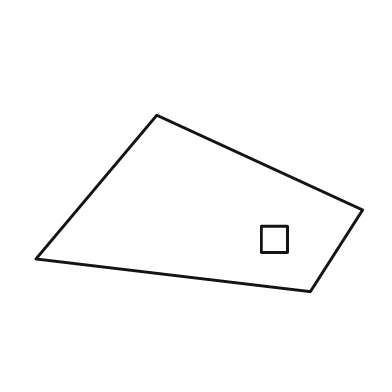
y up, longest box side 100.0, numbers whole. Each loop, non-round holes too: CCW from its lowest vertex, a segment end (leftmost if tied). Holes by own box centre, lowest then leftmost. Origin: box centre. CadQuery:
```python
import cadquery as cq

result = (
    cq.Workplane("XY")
    .moveTo(34.0, -27.0)
    .lineTo(50.0, -2.0)
    .lineTo(-13.0, 27.0)
    .lineTo(-50.0, -17.0)
    .close()
    .moveTo(19.0, -15.0)
    .lineTo(27.0, -15.0)
    .lineTo(27.0, -7.0)
    .lineTo(19.0, -7.0)
    .close()
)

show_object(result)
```